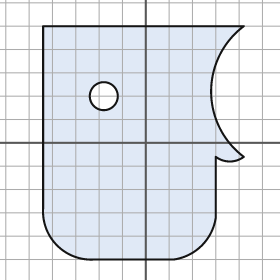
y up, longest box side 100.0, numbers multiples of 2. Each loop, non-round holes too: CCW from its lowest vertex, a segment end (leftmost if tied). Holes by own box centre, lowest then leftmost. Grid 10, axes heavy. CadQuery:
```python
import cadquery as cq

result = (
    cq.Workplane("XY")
    .moveTo(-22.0, -50.0)
    .lineTo(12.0, -50.0)
    .threePointArc((24.0, -44.0), (30.0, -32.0))
    .lineTo(30.0, -6.0)
    .threePointArc((36.0, -8.0), (42.0, -6.0))
    .threePointArc((28.0, 22.0), (42.0, 50.0))
    .lineTo(-44.0, 50.0)
    .lineTo(-44.0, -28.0)
    .threePointArc((-38.0, -44.0), (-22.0, -50.0))
    .close()
    .moveTo(-18.0, 20.0)
    .circle(6.0)
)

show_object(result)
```